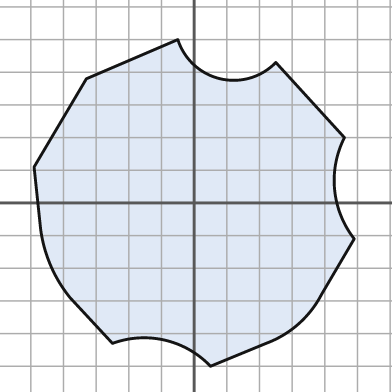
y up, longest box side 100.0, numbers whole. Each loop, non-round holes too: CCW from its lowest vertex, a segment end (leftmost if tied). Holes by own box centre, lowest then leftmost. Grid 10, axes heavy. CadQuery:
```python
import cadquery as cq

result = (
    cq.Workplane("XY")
    .moveTo(5.0, -50.0)
    .lineTo(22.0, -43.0)
    .threePointArc((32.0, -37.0), (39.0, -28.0))
    .lineTo(49.0, -11.0)
    .threePointArc((43.0, 4.0), (46.0, 20.0))
    .lineTo(25.0, 43.0)
    .threePointArc((8.0, 38.0), (-5.0, 50.0))
    .lineTo(-33.0, 38.0)
    .lineTo(-49.0, 11.0)
    .lineTo(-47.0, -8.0)
    .threePointArc((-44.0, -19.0), (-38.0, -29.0))
    .lineTo(-25.0, -43.0)
    .threePointArc((-9.0, -42.0), (5.0, -50.0))
    .close()
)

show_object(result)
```